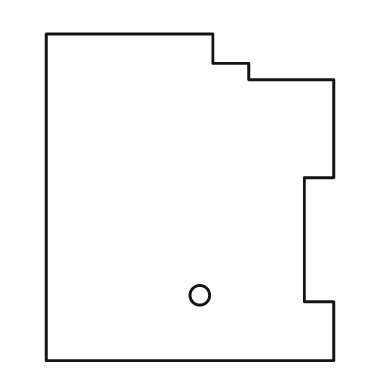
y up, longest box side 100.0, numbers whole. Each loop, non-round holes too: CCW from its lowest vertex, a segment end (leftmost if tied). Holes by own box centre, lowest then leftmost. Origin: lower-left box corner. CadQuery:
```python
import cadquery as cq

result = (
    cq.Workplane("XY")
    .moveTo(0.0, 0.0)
    .lineTo(88.0, 0.0)
    .lineTo(88.0, 18.0)
    .lineTo(79.0, 18.0)
    .lineTo(79.0, 56.0)
    .lineTo(88.0, 56.0)
    .lineTo(88.0, 86.0)
    .lineTo(62.0, 86.0)
    .lineTo(62.0, 91.0)
    .lineTo(51.0, 91.0)
    .lineTo(51.0, 100.0)
    .lineTo(0.0, 100.0)
    .close()
    .moveTo(47.0, 20.0)
    .circle(3.0)
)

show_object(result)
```